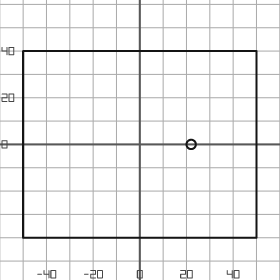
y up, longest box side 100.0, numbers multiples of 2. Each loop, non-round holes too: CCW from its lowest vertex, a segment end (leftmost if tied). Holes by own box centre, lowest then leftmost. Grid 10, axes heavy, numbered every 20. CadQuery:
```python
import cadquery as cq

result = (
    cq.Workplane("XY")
    .moveTo(-50.0, -40.0)
    .lineTo(50.0, -40.0)
    .lineTo(50.0, 40.0)
    .lineTo(-50.0, 40.0)
    .close()
    .moveTo(22.0, 0.0)
    .circle(2.0)
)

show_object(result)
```